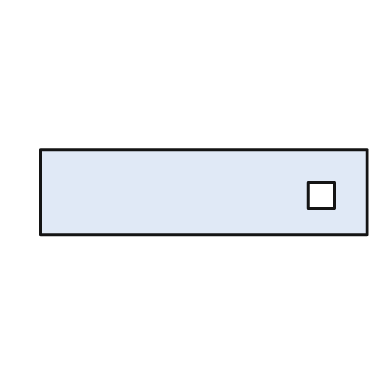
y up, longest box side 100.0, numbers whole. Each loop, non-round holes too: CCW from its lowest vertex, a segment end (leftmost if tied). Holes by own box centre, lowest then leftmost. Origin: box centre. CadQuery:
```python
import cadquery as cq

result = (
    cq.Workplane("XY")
    .moveTo(-50.0, -13.0)
    .lineTo(50.0, -13.0)
    .lineTo(50.0, 13.0)
    .lineTo(-50.0, 13.0)
    .close()
    .moveTo(32.0, -5.0)
    .lineTo(40.0, -5.0)
    .lineTo(40.0, 3.0)
    .lineTo(32.0, 3.0)
    .close()
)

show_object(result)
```